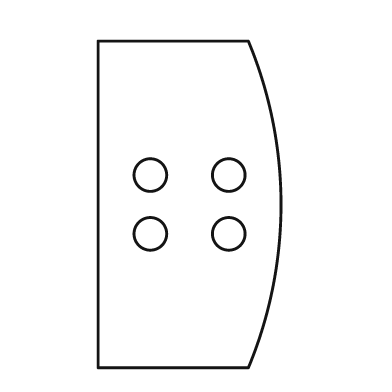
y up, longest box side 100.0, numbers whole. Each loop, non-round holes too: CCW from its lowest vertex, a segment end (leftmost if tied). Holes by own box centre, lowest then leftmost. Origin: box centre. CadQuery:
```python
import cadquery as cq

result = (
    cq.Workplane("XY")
    .moveTo(-28.0, -50.0)
    .lineTo(18.0, -50.0)
    .threePointArc((28.0, 0.0), (18.0, 50.0))
    .lineTo(-28.0, 50.0)
    .close()
    .moveTo(-12.0, -9.0)
    .circle(5.0)
    .moveTo(12.0, -9.0)
    .circle(5.0)
    .moveTo(-12.0, 9.0)
    .circle(5.0)
    .moveTo(12.0, 9.0)
    .circle(5.0)
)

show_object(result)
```